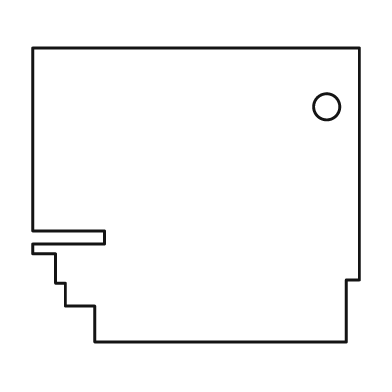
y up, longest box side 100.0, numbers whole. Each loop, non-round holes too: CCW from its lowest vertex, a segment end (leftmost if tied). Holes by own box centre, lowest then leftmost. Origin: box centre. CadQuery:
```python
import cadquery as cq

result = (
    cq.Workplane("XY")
    .moveTo(-31.0, -45.0)
    .lineTo(46.0, -45.0)
    .lineTo(46.0, -26.0)
    .lineTo(50.0, -26.0)
    .lineTo(50.0, 45.0)
    .lineTo(-50.0, 45.0)
    .lineTo(-50.0, -11.0)
    .lineTo(-28.0, -11.0)
    .lineTo(-28.0, -15.0)
    .lineTo(-50.0, -15.0)
    .lineTo(-50.0, -18.0)
    .lineTo(-43.0, -18.0)
    .lineTo(-43.0, -27.0)
    .lineTo(-40.0, -27.0)
    .lineTo(-40.0, -34.0)
    .lineTo(-31.0, -34.0)
    .close()
    .moveTo(40.0, 27.0)
    .circle(4.0)
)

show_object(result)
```